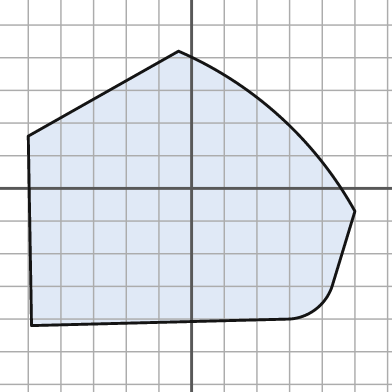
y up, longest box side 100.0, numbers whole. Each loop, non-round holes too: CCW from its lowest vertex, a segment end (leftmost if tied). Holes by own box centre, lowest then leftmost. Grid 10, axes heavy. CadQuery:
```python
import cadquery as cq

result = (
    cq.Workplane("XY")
    .moveTo(-49.0, -42.0)
    .lineTo(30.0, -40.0)
    .threePointArc((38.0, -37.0), (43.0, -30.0))
    .lineTo(50.0, -7.0)
    .threePointArc((27.0, 22.0), (-4.0, 42.0))
    .lineTo(-50.0, 16.0)
    .close()
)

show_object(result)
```